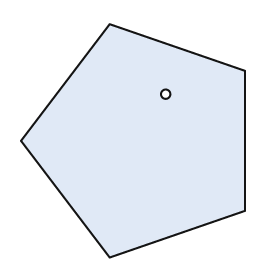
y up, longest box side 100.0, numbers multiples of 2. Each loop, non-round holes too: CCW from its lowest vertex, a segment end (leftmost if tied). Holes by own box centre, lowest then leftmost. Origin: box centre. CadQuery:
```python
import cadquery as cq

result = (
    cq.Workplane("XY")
    .moveTo(-10.0, -50.0)
    .lineTo(48.0, -30.0)
    .lineTo(48.0, 30.0)
    .lineTo(-10.0, 50.0)
    .lineTo(-48.0, 0.0)
    .close()
    .moveTo(14.0, 20.0)
    .circle(2.0)
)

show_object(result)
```